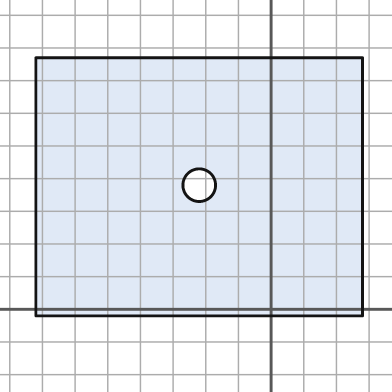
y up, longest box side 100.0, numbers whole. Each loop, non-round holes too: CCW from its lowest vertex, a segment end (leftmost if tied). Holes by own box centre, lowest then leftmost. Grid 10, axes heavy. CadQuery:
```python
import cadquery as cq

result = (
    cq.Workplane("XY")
    .moveTo(-72.0, -2.0)
    .lineTo(28.0, -2.0)
    .lineTo(28.0, 77.0)
    .lineTo(-72.0, 77.0)
    .close()
    .moveTo(-22.0, 38.0)
    .circle(5.0)
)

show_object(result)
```